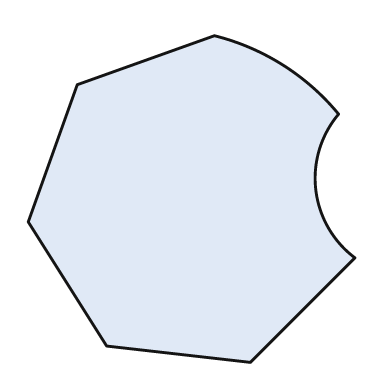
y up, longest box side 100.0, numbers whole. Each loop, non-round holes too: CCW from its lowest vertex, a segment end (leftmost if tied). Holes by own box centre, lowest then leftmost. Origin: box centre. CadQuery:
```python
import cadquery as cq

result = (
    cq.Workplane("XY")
    .moveTo(18.0, -50.0)
    .lineTo(50.0, -18.0)
    .threePointArc((38.0, 3.0), (45.0, 26.0))
    .threePointArc((28.0, 41.0), (7.0, 50.0))
    .lineTo(-35.0, 35.0)
    .lineTo(-50.0, -7.0)
    .lineTo(-26.0, -45.0)
    .close()
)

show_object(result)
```